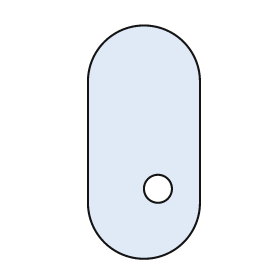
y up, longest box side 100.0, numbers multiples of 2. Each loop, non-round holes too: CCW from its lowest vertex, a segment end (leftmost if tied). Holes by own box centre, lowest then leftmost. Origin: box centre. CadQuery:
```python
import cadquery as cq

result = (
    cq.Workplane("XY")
    .moveTo(-24.0, -26.0)
    .threePointArc((0.0, -50.0), (24.0, -26.0))
    .lineTo(24.0, 26.0)
    .threePointArc((0.0, 50.0), (-24.0, 26.0))
    .close()
    .moveTo(6.0, -20.0)
    .circle(6.0)
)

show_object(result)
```